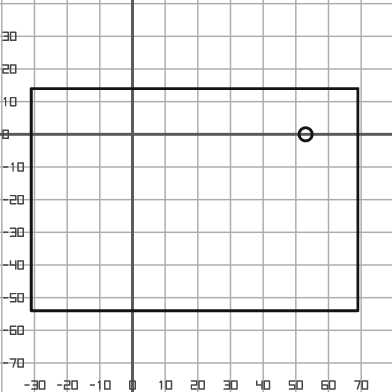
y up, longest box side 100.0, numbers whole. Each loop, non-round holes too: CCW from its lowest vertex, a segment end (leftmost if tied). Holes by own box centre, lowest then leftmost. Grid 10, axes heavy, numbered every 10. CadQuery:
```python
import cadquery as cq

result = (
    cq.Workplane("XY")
    .moveTo(-31.0, -54.0)
    .lineTo(69.0, -54.0)
    .lineTo(69.0, 14.0)
    .lineTo(-31.0, 14.0)
    .close()
    .moveTo(53.0, 0.0)
    .circle(2.0)
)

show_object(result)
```